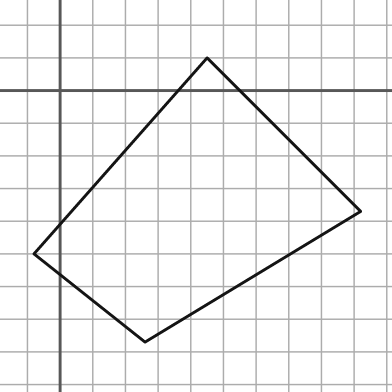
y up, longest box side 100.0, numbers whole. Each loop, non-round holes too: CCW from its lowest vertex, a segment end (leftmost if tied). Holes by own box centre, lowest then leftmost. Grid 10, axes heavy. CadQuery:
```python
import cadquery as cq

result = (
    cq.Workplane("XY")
    .moveTo(26.0, -77.0)
    .lineTo(92.0, -37.0)
    .lineTo(45.0, 10.0)
    .lineTo(-8.0, -50.0)
    .close()
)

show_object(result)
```